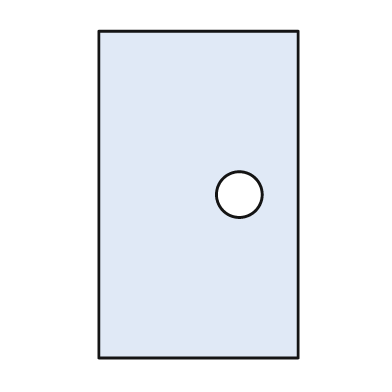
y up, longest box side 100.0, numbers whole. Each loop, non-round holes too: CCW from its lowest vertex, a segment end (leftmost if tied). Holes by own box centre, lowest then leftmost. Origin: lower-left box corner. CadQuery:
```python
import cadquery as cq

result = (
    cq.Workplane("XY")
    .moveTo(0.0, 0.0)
    .lineTo(61.0, 0.0)
    .lineTo(61.0, 100.0)
    .lineTo(0.0, 100.0)
    .close()
    .moveTo(43.0, 50.0)
    .circle(7.0)
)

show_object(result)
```